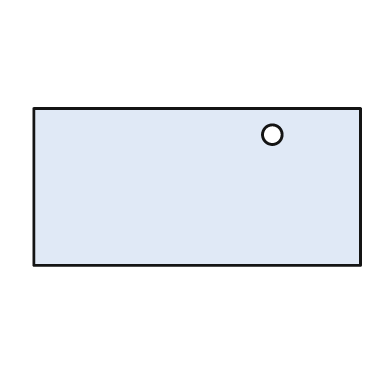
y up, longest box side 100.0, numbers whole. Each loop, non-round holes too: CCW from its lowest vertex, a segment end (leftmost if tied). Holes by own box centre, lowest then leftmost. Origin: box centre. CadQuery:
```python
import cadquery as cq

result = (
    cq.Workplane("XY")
    .moveTo(-50.0, -24.0)
    .lineTo(50.0, -24.0)
    .lineTo(50.0, 24.0)
    .lineTo(-50.0, 24.0)
    .close()
    .moveTo(23.0, 16.0)
    .circle(3.0)
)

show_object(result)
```